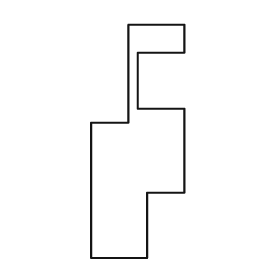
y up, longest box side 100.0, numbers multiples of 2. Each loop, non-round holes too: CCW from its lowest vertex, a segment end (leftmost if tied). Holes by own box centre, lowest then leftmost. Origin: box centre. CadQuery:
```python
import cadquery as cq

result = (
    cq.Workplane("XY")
    .moveTo(-20.0, -50.0)
    .lineTo(4.0, -50.0)
    .lineTo(4.0, -22.0)
    .lineTo(20.0, -22.0)
    .lineTo(20.0, 14.0)
    .lineTo(0.0, 14.0)
    .lineTo(0.0, 38.0)
    .lineTo(20.0, 38.0)
    .lineTo(20.0, 50.0)
    .lineTo(-4.0, 50.0)
    .lineTo(-4.0, 8.0)
    .lineTo(-20.0, 8.0)
    .close()
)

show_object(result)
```